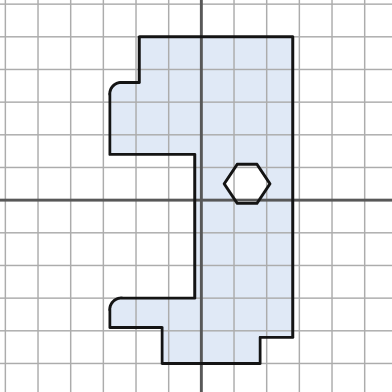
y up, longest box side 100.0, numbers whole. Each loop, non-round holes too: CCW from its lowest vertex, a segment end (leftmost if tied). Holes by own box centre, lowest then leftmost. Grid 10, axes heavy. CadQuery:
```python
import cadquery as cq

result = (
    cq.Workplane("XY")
    .moveTo(-12.0, -50.0)
    .lineTo(18.0, -50.0)
    .lineTo(18.0, -42.0)
    .lineTo(28.0, -42.0)
    .lineTo(28.0, 50.0)
    .lineTo(-19.0, 50.0)
    .lineTo(-19.0, 36.0)
    .lineTo(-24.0, 36.0)
    .threePointArc((-27.0, 35.0), (-28.0, 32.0))
    .lineTo(-28.0, 14.0)
    .lineTo(-2.0, 14.0)
    .lineTo(-2.0, -30.0)
    .lineTo(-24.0, -30.0)
    .threePointArc((-27.0, -31.0), (-28.0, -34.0))
    .lineTo(-28.0, -39.0)
    .lineTo(-12.0, -39.0)
    .close()
    .moveTo(11.0, -1.0)
    .lineTo(17.0, -1.0)
    .lineTo(21.0, 5.0)
    .lineTo(17.0, 11.0)
    .lineTo(11.0, 11.0)
    .lineTo(7.0, 5.0)
    .close()
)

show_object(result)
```